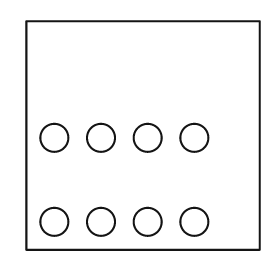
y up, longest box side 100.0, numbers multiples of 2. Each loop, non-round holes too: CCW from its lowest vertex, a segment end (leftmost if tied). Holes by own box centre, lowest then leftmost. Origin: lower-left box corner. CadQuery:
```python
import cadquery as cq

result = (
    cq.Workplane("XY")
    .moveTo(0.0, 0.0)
    .lineTo(100.0, 0.0)
    .lineTo(100.0, 98.0)
    .lineTo(0.0, 98.0)
    .close()
    .moveTo(12.0, 12.0)
    .circle(6.0)
    .moveTo(32.0, 12.0)
    .circle(6.0)
    .moveTo(52.0, 12.0)
    .circle(6.0)
    .moveTo(72.0, 12.0)
    .circle(6.0)
    .moveTo(12.0, 48.0)
    .circle(6.0)
    .moveTo(32.0, 48.0)
    .circle(6.0)
    .moveTo(52.0, 48.0)
    .circle(6.0)
    .moveTo(72.0, 48.0)
    .circle(6.0)
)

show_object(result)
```